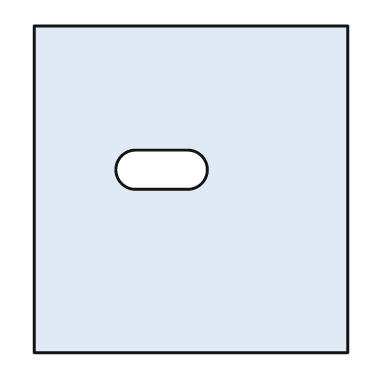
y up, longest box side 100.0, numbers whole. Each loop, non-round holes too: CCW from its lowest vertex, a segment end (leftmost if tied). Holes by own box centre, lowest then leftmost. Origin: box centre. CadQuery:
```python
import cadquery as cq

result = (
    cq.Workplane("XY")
    .moveTo(-48.0, -50.0)
    .lineTo(48.0, -50.0)
    .lineTo(48.0, 50.0)
    .lineTo(-48.0, 50.0)
    .close()
    .moveTo(-17.0, 0.0)
    .lineTo(-1.0, 0.0)
    .threePointArc((5.0, 6.0), (-1.0, 12.0))
    .lineTo(-17.0, 12.0)
    .threePointArc((-23.0, 6.0), (-17.0, 0.0))
    .close()
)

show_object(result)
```